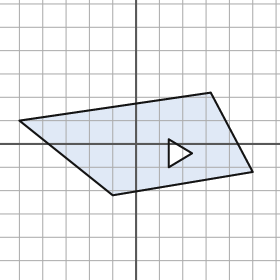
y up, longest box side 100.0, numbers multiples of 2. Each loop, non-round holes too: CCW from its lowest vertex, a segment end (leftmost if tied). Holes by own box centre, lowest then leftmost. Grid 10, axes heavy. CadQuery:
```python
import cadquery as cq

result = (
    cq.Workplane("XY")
    .moveTo(-10.0, -22.0)
    .lineTo(50.0, -12.0)
    .lineTo(32.0, 22.0)
    .lineTo(-50.0, 10.0)
    .close()
    .moveTo(14.0, -10.0)
    .lineTo(24.0, -4.0)
    .lineTo(14.0, 2.0)
    .close()
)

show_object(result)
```